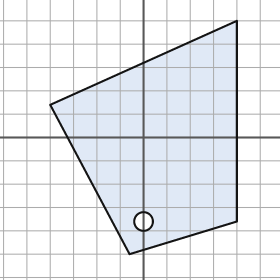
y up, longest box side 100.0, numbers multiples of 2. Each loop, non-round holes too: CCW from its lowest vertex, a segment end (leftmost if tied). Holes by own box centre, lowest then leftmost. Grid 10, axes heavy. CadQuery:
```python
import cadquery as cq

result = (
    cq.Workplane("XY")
    .moveTo(-6.0, -50.0)
    .lineTo(40.0, -36.0)
    .lineTo(40.0, 50.0)
    .lineTo(-40.0, 14.0)
    .close()
    .moveTo(0.0, -36.0)
    .circle(4.0)
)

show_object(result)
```